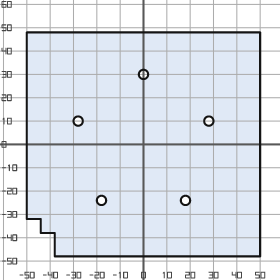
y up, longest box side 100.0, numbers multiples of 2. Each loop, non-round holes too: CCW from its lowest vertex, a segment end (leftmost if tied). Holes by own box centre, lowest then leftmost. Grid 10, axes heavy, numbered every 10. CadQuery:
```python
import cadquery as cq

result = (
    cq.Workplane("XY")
    .moveTo(-38.0, -48.0)
    .lineTo(50.0, -48.0)
    .lineTo(50.0, 48.0)
    .lineTo(-50.0, 48.0)
    .lineTo(-50.0, -32.0)
    .lineTo(-44.0, -32.0)
    .lineTo(-44.0, -38.0)
    .lineTo(-38.0, -38.0)
    .close()
    .moveTo(-18.0, -24.0)
    .circle(2.0)
    .moveTo(18.0, -24.0)
    .circle(2.0)
    .moveTo(-28.0, 10.0)
    .circle(2.0)
    .moveTo(28.0, 10.0)
    .circle(2.0)
    .moveTo(0.0, 30.0)
    .circle(2.0)
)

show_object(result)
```